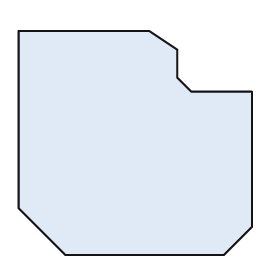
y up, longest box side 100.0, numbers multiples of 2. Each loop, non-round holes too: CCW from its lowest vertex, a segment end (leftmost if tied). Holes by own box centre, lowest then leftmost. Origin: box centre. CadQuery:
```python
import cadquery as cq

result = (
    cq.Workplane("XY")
    .moveTo(-30.0, -48.0)
    .lineTo(38.0, -48.0)
    .lineTo(50.0, -36.0)
    .lineTo(50.0, 22.0)
    .lineTo(24.0, 22.0)
    .lineTo(18.0, 28.0)
    .lineTo(18.0, 40.0)
    .lineTo(6.0, 48.0)
    .lineTo(-50.0, 48.0)
    .lineTo(-50.0, -28.0)
    .close()
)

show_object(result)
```